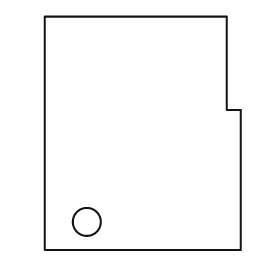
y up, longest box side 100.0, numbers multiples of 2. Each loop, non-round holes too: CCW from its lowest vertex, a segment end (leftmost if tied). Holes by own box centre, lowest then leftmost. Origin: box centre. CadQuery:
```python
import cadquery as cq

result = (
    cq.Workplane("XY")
    .moveTo(-42.0, -50.0)
    .lineTo(42.0, -50.0)
    .lineTo(42.0, 10.0)
    .lineTo(36.0, 10.0)
    .lineTo(36.0, 50.0)
    .lineTo(-42.0, 50.0)
    .close()
    .moveTo(-24.0, -38.0)
    .circle(6.0)
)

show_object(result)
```